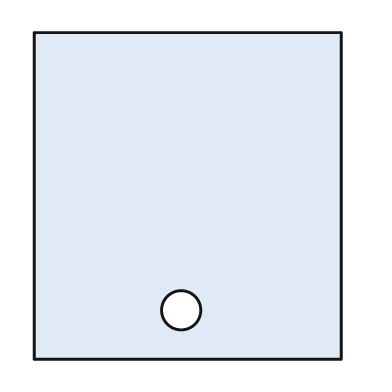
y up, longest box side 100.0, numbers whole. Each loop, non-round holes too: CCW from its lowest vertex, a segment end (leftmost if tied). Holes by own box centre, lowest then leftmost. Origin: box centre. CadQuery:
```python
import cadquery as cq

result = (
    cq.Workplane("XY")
    .moveTo(-47.0, -50.0)
    .lineTo(47.0, -50.0)
    .lineTo(47.0, 50.0)
    .lineTo(-47.0, 50.0)
    .close()
    .moveTo(-2.0, -35.0)
    .circle(6.0)
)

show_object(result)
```